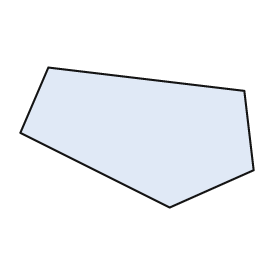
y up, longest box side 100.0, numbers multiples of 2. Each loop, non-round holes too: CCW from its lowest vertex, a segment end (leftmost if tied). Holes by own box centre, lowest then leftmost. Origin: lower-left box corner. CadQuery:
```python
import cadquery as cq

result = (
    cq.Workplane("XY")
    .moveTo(64.0, 0.0)
    .lineTo(100.0, 16.0)
    .lineTo(96.0, 50.0)
    .lineTo(12.0, 60.0)
    .lineTo(0.0, 32.0)
    .close()
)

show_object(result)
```